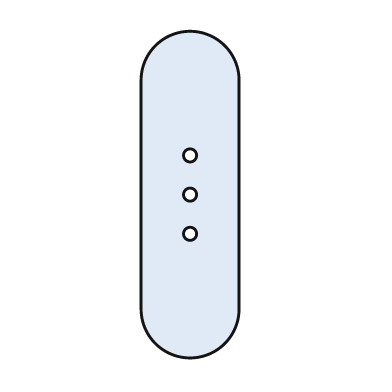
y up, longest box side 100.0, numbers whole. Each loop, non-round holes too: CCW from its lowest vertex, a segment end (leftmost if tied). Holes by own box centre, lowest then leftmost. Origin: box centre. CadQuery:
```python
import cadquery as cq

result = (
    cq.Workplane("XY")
    .moveTo(-15.0, -35.0)
    .threePointArc((0.0, -50.0), (15.0, -35.0))
    .lineTo(15.0, 35.0)
    .threePointArc((0.0, 50.0), (-15.0, 35.0))
    .close()
    .moveTo(0.0, -12.0)
    .circle(2.0)
    .moveTo(0.0, 0.0)
    .circle(2.0)
    .moveTo(0.0, 12.0)
    .circle(2.0)
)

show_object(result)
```